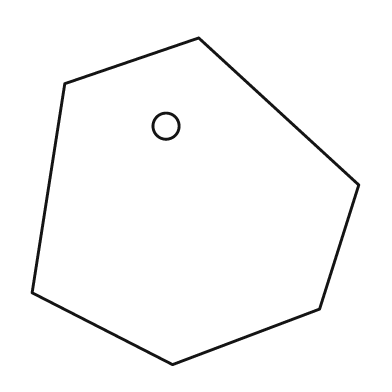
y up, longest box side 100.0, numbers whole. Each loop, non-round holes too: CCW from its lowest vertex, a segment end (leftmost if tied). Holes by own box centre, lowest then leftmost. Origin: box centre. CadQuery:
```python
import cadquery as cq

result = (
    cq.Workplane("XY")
    .moveTo(-7.0, -50.0)
    .lineTo(38.0, -33.0)
    .lineTo(50.0, 5.0)
    .lineTo(1.0, 50.0)
    .lineTo(-40.0, 36.0)
    .lineTo(-50.0, -28.0)
    .close()
    .moveTo(-9.0, 23.0)
    .circle(4.0)
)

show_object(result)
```